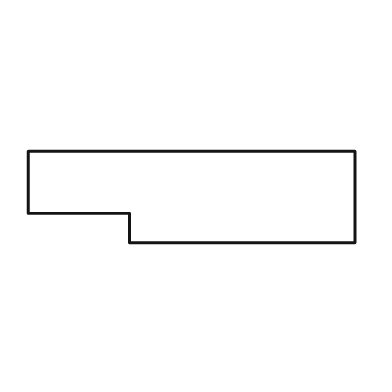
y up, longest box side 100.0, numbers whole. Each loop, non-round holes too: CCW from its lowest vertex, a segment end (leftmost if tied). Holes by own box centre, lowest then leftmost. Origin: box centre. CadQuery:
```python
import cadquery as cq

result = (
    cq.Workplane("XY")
    .moveTo(-19.0, -14.0)
    .lineTo(50.0, -14.0)
    .lineTo(50.0, 14.0)
    .lineTo(-50.0, 14.0)
    .lineTo(-50.0, -5.0)
    .lineTo(-19.0, -5.0)
    .close()
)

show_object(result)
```